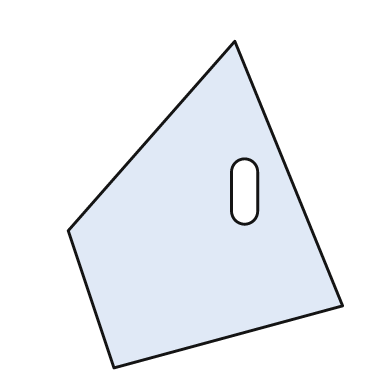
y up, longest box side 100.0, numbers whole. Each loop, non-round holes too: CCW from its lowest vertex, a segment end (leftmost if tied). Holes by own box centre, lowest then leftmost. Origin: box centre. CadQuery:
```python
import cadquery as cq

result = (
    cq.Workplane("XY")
    .moveTo(-28.0, -50.0)
    .lineTo(42.0, -31.0)
    .lineTo(9.0, 50.0)
    .lineTo(-42.0, -8.0)
    .close()
    .moveTo(8.0, -2.0)
    .threePointArc((12.0, -6.0), (16.0, -2.0))
    .lineTo(16.0, 10.0)
    .threePointArc((12.0, 14.0), (8.0, 10.0))
    .close()
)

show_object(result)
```